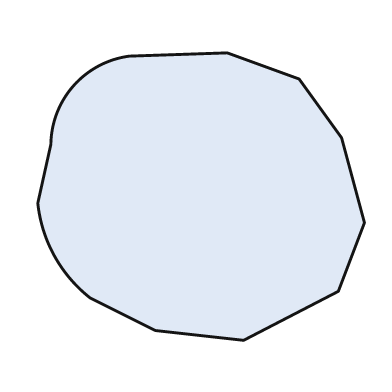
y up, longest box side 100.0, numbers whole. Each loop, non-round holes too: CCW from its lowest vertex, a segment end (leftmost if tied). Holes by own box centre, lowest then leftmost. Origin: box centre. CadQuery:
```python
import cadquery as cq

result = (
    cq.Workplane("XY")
    .moveTo(13.0, -44.0)
    .lineTo(42.0, -29.0)
    .lineTo(50.0, -8.0)
    .lineTo(43.0, 18.0)
    .lineTo(30.0, 36.0)
    .lineTo(8.0, 44.0)
    .lineTo(-22.0, 43.0)
    .threePointArc((-39.0, 34.0), (-46.0, 16.0))
    .lineTo(-50.0, -2.0)
    .threePointArc((-45.0, -18.0), (-34.0, -31.0))
    .lineTo(-14.0, -41.0)
    .close()
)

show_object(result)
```